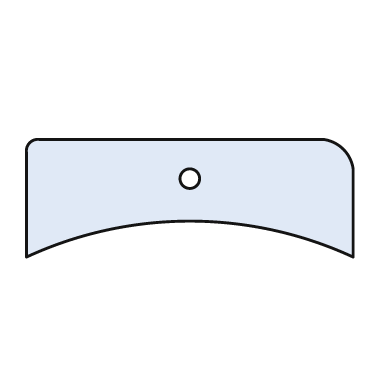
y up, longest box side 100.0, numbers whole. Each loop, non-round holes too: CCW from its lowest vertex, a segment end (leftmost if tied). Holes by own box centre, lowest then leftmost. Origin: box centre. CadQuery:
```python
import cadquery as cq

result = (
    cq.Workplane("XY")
    .moveTo(-50.0, -18.0)
    .threePointArc((0.0, -7.0), (50.0, -18.0))
    .lineTo(50.0, 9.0)
    .threePointArc((47.0, 15.0), (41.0, 18.0))
    .lineTo(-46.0, 18.0)
    .threePointArc((-49.0, 17.0), (-50.0, 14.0))
    .close()
    .moveTo(0.0, 6.0)
    .circle(3.0)
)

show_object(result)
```